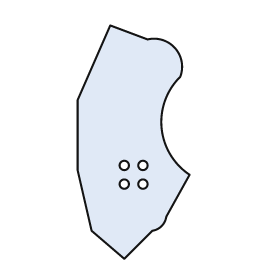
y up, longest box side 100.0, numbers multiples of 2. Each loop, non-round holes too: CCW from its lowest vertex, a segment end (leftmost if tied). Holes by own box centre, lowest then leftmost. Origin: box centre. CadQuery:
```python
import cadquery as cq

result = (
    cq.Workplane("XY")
    .moveTo(-4.0, -50.0)
    .lineTo(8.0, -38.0)
    .threePointArc((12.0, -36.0), (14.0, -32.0))
    .lineTo(24.0, -14.0)
    .threePointArc((12.0, 6.0), (20.0, 28.0))
    .threePointArc((18.0, 40.0), (6.0, 44.0))
    .lineTo(-10.0, 50.0)
    .lineTo(-24.0, 18.0)
    .lineTo(-24.0, -12.0)
    .lineTo(-18.0, -38.0)
    .close()
    .moveTo(-4.0, -18.0)
    .circle(2.0)
    .moveTo(4.0, -18.0)
    .circle(2.0)
    .moveTo(-4.0, -10.0)
    .circle(2.0)
    .moveTo(4.0, -10.0)
    .circle(2.0)
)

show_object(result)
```